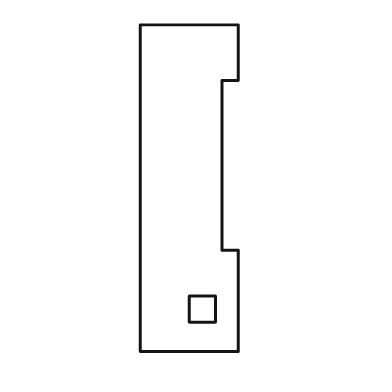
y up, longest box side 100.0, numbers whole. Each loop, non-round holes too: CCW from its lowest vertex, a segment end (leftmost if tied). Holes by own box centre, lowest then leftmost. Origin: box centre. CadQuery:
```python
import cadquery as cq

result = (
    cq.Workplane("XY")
    .moveTo(-15.0, -50.0)
    .lineTo(15.0, -50.0)
    .lineTo(15.0, -19.0)
    .lineTo(10.0, -19.0)
    .lineTo(10.0, 33.0)
    .lineTo(15.0, 33.0)
    .lineTo(15.0, 50.0)
    .lineTo(-15.0, 50.0)
    .close()
    .moveTo(0.0, -41.0)
    .lineTo(8.0, -41.0)
    .lineTo(8.0, -33.0)
    .lineTo(0.0, -33.0)
    .close()
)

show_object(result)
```